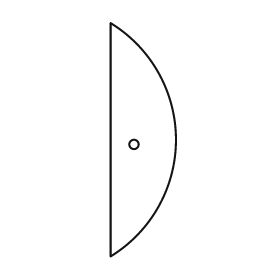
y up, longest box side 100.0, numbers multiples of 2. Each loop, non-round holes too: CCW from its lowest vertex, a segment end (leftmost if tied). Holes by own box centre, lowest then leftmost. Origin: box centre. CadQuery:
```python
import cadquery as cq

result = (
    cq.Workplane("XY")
    .moveTo(-14.0, -50.0)
    .threePointArc((14.0, 0.0), (-14.0, 50.0))
    .close()
    .moveTo(-4.0, -2.0)
    .circle(2.0)
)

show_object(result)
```